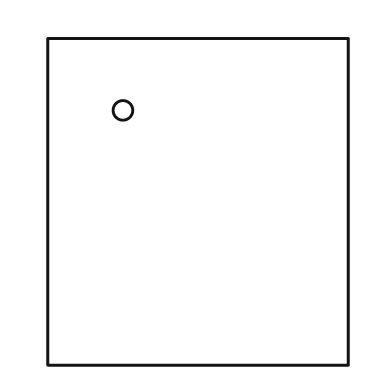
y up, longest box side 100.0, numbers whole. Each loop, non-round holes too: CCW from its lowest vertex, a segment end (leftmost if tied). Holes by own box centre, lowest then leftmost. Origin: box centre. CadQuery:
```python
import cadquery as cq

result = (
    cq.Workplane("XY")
    .moveTo(-46.0, -50.0)
    .lineTo(46.0, -50.0)
    .lineTo(46.0, 50.0)
    .lineTo(-46.0, 50.0)
    .close()
    .moveTo(-23.0, 28.0)
    .circle(3.0)
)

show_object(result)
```